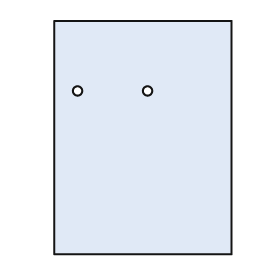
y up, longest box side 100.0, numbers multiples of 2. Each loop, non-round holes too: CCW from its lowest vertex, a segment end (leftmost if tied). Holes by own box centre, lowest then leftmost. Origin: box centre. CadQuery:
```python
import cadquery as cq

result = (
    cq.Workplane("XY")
    .moveTo(-38.0, -50.0)
    .lineTo(38.0, -50.0)
    .lineTo(38.0, 50.0)
    .lineTo(-38.0, 50.0)
    .close()
    .moveTo(-28.0, 20.0)
    .circle(2.0)
    .moveTo(2.0, 20.0)
    .circle(2.0)
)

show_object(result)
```